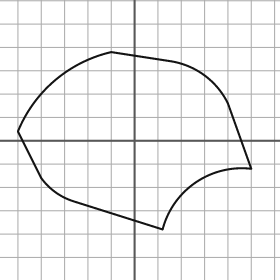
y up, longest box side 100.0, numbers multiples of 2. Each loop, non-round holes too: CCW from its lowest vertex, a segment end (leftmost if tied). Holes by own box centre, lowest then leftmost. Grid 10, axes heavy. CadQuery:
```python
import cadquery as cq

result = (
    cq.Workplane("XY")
    .moveTo(12.0, -38.0)
    .threePointArc((26.0, -18.0), (50.0, -12.0))
    .lineTo(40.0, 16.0)
    .threePointArc((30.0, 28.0), (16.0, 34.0))
    .lineTo(-10.0, 38.0)
    .threePointArc((-34.0, 26.0), (-50.0, 4.0))
    .lineTo(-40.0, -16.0)
    .threePointArc((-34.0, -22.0), (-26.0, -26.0))
    .close()
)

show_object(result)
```